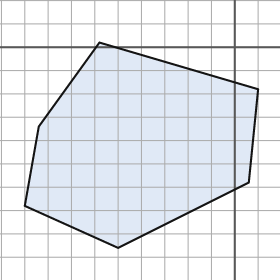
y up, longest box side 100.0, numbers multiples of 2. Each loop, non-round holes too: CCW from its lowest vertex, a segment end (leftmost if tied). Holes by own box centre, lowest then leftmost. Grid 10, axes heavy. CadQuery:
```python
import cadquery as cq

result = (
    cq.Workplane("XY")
    .moveTo(-50.0, -86.0)
    .lineTo(6.0, -58.0)
    .lineTo(10.0, -18.0)
    .lineTo(-58.0, 2.0)
    .lineTo(-84.0, -34.0)
    .lineTo(-90.0, -68.0)
    .close()
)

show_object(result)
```